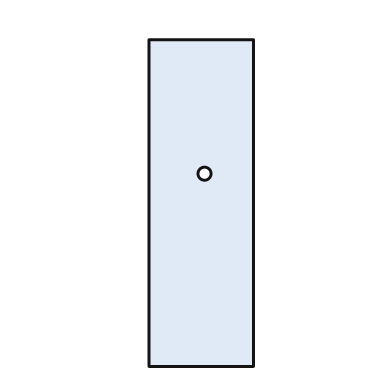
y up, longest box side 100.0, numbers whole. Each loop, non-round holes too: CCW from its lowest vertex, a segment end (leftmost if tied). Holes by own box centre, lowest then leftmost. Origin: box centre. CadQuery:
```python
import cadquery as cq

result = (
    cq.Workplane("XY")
    .moveTo(-16.0, -50.0)
    .lineTo(16.0, -50.0)
    .lineTo(16.0, 50.0)
    .lineTo(-16.0, 50.0)
    .close()
    .moveTo(1.0, 9.0)
    .circle(2.0)
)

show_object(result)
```